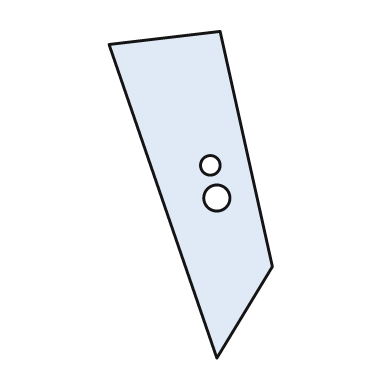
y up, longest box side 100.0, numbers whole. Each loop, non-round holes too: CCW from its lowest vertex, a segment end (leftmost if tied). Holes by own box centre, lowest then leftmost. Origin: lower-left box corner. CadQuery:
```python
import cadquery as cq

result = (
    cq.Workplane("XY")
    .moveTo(33.0, 0.0)
    .lineTo(50.0, 28.0)
    .lineTo(34.0, 100.0)
    .lineTo(0.0, 96.0)
    .close()
    .moveTo(33.0, 49.0)
    .circle(4.0)
    .moveTo(31.0, 59.0)
    .circle(3.0)
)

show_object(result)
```